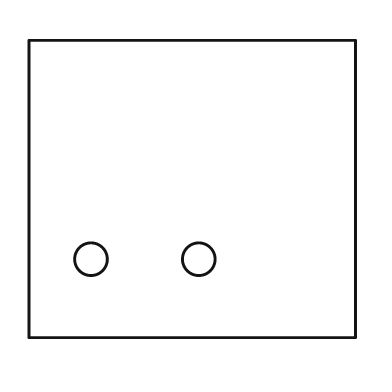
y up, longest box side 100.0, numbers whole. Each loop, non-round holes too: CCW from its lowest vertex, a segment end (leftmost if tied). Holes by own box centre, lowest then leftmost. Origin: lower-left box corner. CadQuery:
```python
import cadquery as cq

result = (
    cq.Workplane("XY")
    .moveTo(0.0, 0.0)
    .lineTo(100.0, 0.0)
    .lineTo(100.0, 91.0)
    .lineTo(0.0, 91.0)
    .close()
    .moveTo(19.0, 24.0)
    .circle(5.0)
    .moveTo(52.0, 24.0)
    .circle(5.0)
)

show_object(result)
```